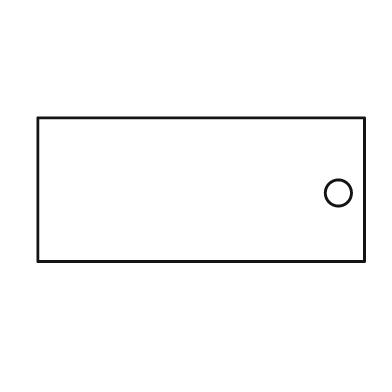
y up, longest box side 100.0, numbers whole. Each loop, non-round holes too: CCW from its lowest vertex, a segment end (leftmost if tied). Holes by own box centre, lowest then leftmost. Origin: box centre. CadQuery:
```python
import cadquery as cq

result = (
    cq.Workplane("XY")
    .moveTo(-50.0, -22.0)
    .lineTo(50.0, -22.0)
    .lineTo(50.0, 22.0)
    .lineTo(-50.0, 22.0)
    .close()
    .moveTo(42.0, -1.0)
    .circle(4.0)
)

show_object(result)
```